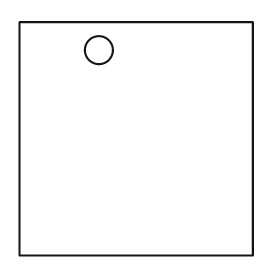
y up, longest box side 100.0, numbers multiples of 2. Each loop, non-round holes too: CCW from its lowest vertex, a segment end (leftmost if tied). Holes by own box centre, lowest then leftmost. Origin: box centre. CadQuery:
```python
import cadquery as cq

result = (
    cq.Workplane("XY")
    .moveTo(-50.0, -50.0)
    .lineTo(50.0, -50.0)
    .lineTo(50.0, 50.0)
    .lineTo(-50.0, 50.0)
    .close()
    .moveTo(-16.0, 38.0)
    .circle(6.0)
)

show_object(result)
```